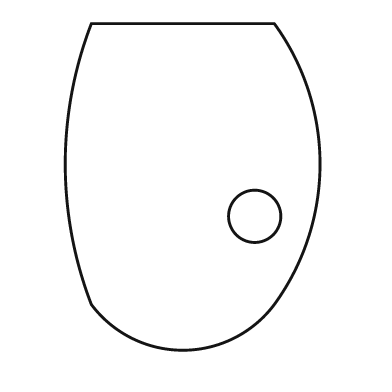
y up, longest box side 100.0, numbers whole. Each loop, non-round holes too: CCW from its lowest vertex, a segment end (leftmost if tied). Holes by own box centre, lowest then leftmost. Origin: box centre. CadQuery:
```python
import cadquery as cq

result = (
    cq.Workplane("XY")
    .moveTo(-31.0, -36.0)
    .threePointArc((-3.0, -50.0), (25.0, -36.0))
    .threePointArc((39.0, 7.0), (25.0, 50.0))
    .lineTo(-31.0, 50.0)
    .threePointArc((-39.0, 7.0), (-31.0, -36.0))
    .close()
    .moveTo(19.0, -9.0)
    .circle(8.0)
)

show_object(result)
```